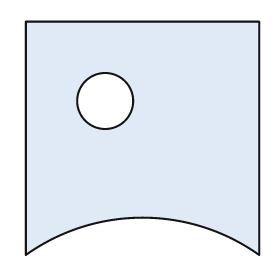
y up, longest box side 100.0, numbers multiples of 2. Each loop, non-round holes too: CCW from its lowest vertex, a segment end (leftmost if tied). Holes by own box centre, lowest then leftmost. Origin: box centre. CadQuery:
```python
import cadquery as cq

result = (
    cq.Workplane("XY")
    .moveTo(-50.0, -50.0)
    .threePointArc((0.0, -34.0), (50.0, -50.0))
    .lineTo(50.0, 50.0)
    .lineTo(-50.0, 50.0)
    .close()
    .moveTo(-16.0, 16.0)
    .circle(12.0)
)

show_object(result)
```